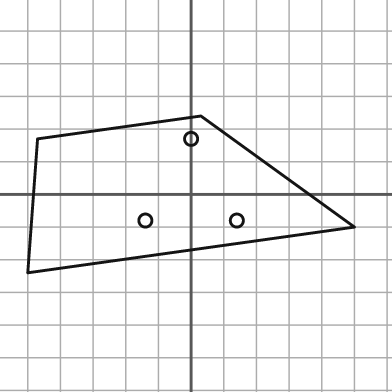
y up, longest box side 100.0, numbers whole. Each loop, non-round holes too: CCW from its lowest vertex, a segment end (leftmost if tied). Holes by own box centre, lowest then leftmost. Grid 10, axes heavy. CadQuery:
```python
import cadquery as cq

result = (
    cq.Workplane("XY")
    .moveTo(-50.0, -24.0)
    .lineTo(50.0, -10.0)
    .lineTo(3.0, 24.0)
    .lineTo(-47.0, 17.0)
    .close()
    .moveTo(-14.0, -8.0)
    .circle(2.0)
    .moveTo(14.0, -8.0)
    .circle(2.0)
    .moveTo(0.0, 17.0)
    .circle(2.0)
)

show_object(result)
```